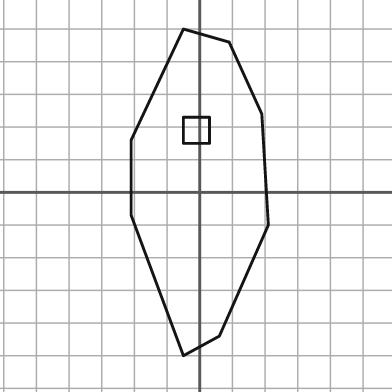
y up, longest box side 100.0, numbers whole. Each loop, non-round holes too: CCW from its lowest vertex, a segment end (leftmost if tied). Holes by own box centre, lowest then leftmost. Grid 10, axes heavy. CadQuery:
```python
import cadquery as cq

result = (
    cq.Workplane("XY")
    .moveTo(-5.0, -50.0)
    .lineTo(6.0, -44.0)
    .lineTo(21.0, -10.0)
    .lineTo(19.0, 24.0)
    .lineTo(9.0, 46.0)
    .lineTo(-5.0, 50.0)
    .lineTo(-21.0, 16.0)
    .lineTo(-21.0, -7.0)
    .close()
    .moveTo(-5.0, 15.0)
    .lineTo(3.0, 15.0)
    .lineTo(3.0, 23.0)
    .lineTo(-5.0, 23.0)
    .close()
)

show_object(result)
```